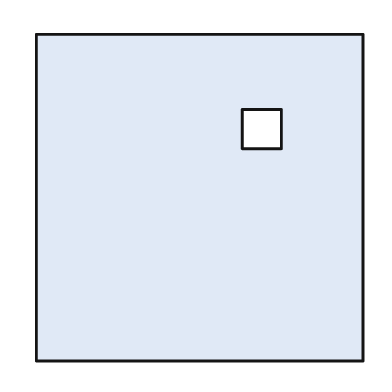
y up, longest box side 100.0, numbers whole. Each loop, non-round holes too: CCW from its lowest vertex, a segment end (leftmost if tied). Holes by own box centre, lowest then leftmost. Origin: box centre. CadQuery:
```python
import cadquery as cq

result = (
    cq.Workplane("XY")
    .moveTo(-50.0, -50.0)
    .lineTo(50.0, -50.0)
    .lineTo(50.0, 50.0)
    .lineTo(-50.0, 50.0)
    .close()
    .moveTo(13.0, 15.0)
    .lineTo(25.0, 15.0)
    .lineTo(25.0, 27.0)
    .lineTo(13.0, 27.0)
    .close()
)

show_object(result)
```